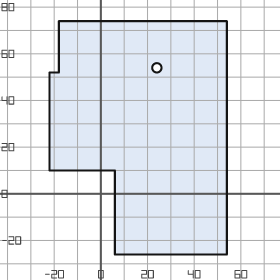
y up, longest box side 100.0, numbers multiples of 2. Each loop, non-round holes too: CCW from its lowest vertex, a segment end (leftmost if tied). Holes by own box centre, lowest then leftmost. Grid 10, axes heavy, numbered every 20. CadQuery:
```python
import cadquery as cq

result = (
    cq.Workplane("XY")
    .moveTo(6.0, -26.0)
    .lineTo(54.0, -26.0)
    .lineTo(54.0, 74.0)
    .lineTo(-18.0, 74.0)
    .lineTo(-18.0, 52.0)
    .lineTo(-22.0, 52.0)
    .lineTo(-22.0, 10.0)
    .lineTo(6.0, 10.0)
    .close()
    .moveTo(24.0, 54.0)
    .circle(2.0)
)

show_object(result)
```